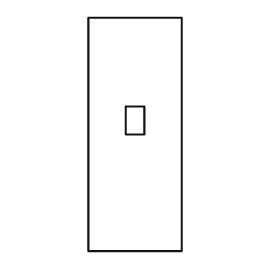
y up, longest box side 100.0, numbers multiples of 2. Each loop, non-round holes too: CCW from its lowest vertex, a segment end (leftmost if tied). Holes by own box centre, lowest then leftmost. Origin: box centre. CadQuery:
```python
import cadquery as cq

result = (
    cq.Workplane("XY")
    .moveTo(-20.0, -50.0)
    .lineTo(20.0, -50.0)
    .lineTo(20.0, 50.0)
    .lineTo(-20.0, 50.0)
    .close()
    .moveTo(-4.0, 0.0)
    .lineTo(4.0, 0.0)
    .lineTo(4.0, 12.0)
    .lineTo(-4.0, 12.0)
    .close()
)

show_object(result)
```